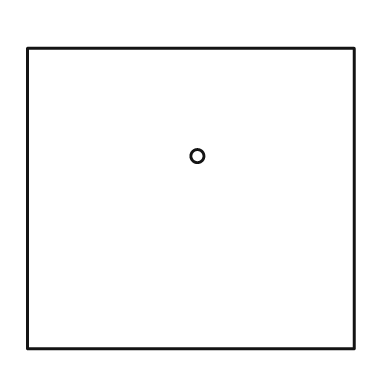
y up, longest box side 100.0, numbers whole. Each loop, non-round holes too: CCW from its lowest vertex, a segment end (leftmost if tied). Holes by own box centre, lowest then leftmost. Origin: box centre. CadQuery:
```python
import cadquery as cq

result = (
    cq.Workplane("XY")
    .moveTo(-50.0, -46.0)
    .lineTo(50.0, -46.0)
    .lineTo(50.0, 46.0)
    .lineTo(-50.0, 46.0)
    .close()
    .moveTo(2.0, 13.0)
    .circle(2.0)
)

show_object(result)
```